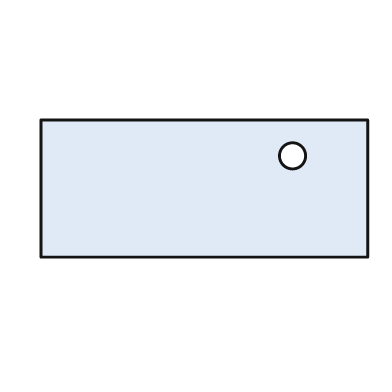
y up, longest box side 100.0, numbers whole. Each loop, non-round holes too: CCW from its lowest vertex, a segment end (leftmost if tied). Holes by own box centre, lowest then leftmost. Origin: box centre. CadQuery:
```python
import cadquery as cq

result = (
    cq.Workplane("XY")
    .moveTo(-50.0, -21.0)
    .lineTo(50.0, -21.0)
    .lineTo(50.0, 21.0)
    .lineTo(-50.0, 21.0)
    .close()
    .moveTo(27.0, 10.0)
    .circle(4.0)
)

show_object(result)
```